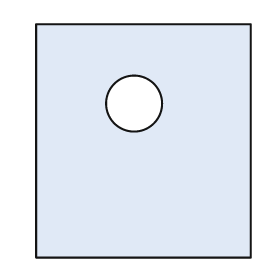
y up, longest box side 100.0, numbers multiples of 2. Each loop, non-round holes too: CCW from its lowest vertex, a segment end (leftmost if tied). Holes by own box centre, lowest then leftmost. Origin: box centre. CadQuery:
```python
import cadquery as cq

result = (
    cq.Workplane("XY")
    .moveTo(-46.0, -50.0)
    .lineTo(46.0, -50.0)
    .lineTo(46.0, 50.0)
    .lineTo(-46.0, 50.0)
    .close()
    .moveTo(-4.0, 16.0)
    .circle(12.0)
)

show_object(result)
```